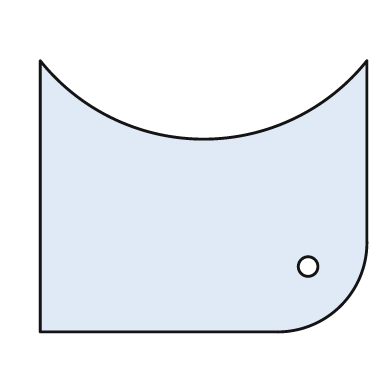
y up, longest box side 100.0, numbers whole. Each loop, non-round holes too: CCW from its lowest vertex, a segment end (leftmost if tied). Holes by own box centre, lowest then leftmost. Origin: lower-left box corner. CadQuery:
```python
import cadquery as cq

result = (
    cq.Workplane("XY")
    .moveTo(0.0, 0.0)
    .lineTo(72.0, 0.0)
    .threePointArc((92.0, 8.0), (100.0, 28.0))
    .lineTo(100.0, 83.0)
    .threePointArc((50.0, 59.0), (0.0, 83.0))
    .close()
    .moveTo(82.0, 20.0)
    .circle(3.0)
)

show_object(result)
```